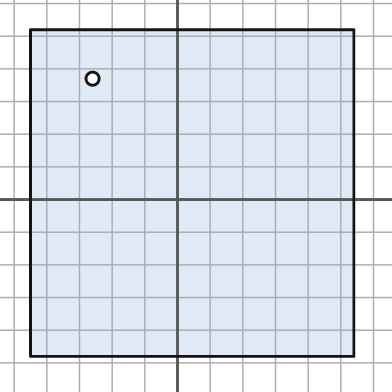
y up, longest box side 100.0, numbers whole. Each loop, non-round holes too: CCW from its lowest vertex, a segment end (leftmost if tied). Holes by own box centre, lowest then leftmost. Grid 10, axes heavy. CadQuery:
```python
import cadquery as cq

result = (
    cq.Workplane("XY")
    .moveTo(-45.0, -48.0)
    .lineTo(54.0, -48.0)
    .lineTo(54.0, 52.0)
    .lineTo(-45.0, 52.0)
    .close()
    .moveTo(-26.0, 37.0)
    .circle(2.0)
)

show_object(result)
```